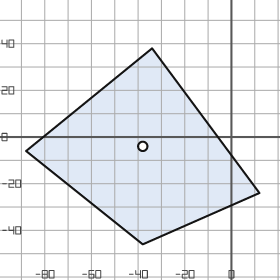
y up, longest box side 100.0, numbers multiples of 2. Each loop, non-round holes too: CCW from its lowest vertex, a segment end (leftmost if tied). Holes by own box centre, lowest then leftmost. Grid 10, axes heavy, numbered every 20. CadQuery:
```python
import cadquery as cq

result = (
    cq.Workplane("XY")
    .moveTo(-38.0, -46.0)
    .lineTo(12.0, -24.0)
    .lineTo(-34.0, 38.0)
    .lineTo(-88.0, -6.0)
    .close()
    .moveTo(-38.0, -4.0)
    .circle(2.0)
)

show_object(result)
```